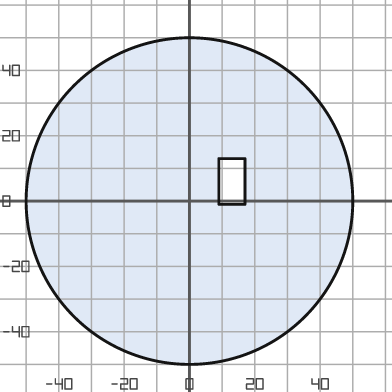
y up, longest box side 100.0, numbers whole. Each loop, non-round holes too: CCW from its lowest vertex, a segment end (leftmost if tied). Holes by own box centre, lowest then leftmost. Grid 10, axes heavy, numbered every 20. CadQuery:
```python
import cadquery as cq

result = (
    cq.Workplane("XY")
    .moveTo(0.0, 0.0)
    .circle(50.0)
    .moveTo(9.0, -1.0)
    .lineTo(17.0, -1.0)
    .lineTo(17.0, 13.0)
    .lineTo(9.0, 13.0)
    .close()
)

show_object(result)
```